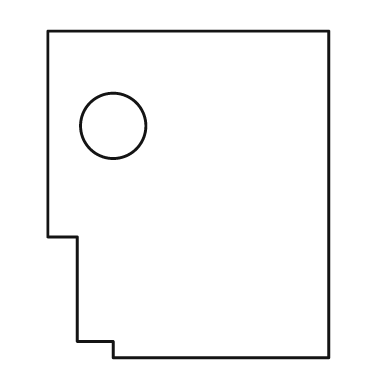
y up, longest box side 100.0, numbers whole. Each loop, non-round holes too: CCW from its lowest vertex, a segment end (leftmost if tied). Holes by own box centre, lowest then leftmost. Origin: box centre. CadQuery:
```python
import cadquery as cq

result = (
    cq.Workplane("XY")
    .moveTo(-23.0, -50.0)
    .lineTo(43.0, -50.0)
    .lineTo(43.0, 50.0)
    .lineTo(-43.0, 50.0)
    .lineTo(-43.0, -13.0)
    .lineTo(-34.0, -13.0)
    .lineTo(-34.0, -45.0)
    .lineTo(-23.0, -45.0)
    .close()
    .moveTo(-23.0, 21.0)
    .circle(10.0)
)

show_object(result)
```